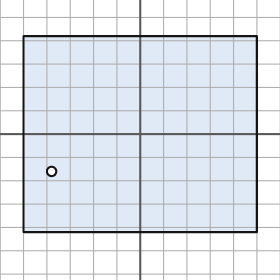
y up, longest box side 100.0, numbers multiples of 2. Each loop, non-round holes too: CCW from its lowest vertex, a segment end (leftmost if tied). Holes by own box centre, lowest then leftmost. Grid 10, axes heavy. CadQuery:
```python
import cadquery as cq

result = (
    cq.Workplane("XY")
    .moveTo(-50.0, -42.0)
    .lineTo(50.0, -42.0)
    .lineTo(50.0, 42.0)
    .lineTo(-50.0, 42.0)
    .close()
    .moveTo(-38.0, -16.0)
    .circle(2.0)
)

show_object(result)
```